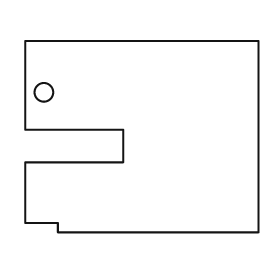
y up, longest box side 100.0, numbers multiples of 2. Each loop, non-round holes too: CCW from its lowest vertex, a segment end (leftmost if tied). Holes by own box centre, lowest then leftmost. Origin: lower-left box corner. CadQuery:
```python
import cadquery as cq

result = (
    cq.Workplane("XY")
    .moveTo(14.0, 0.0)
    .lineTo(100.0, 0.0)
    .lineTo(100.0, 82.0)
    .lineTo(0.0, 82.0)
    .lineTo(0.0, 44.0)
    .lineTo(42.0, 44.0)
    .lineTo(42.0, 30.0)
    .lineTo(0.0, 30.0)
    .lineTo(0.0, 4.0)
    .lineTo(14.0, 4.0)
    .close()
    .moveTo(8.0, 60.0)
    .circle(4.0)
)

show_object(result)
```